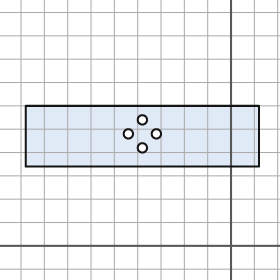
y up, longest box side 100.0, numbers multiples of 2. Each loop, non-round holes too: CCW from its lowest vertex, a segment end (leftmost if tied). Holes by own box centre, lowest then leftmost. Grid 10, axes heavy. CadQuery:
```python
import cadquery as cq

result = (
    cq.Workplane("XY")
    .moveTo(-88.0, 34.0)
    .lineTo(12.0, 34.0)
    .lineTo(12.0, 60.0)
    .lineTo(-88.0, 60.0)
    .close()
    .moveTo(-38.0, 42.0)
    .circle(2.0)
    .moveTo(-44.0, 48.0)
    .circle(2.0)
    .moveTo(-32.0, 48.0)
    .circle(2.0)
    .moveTo(-38.0, 54.0)
    .circle(2.0)
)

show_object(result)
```